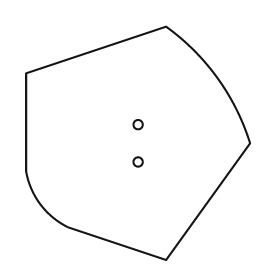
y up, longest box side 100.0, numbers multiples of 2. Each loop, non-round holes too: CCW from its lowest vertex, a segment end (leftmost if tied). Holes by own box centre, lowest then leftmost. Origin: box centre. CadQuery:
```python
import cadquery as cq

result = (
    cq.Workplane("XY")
    .moveTo(12.0, -50.0)
    .lineTo(48.0, 0.0)
    .threePointArc((34.0, 28.0), (12.0, 50.0))
    .lineTo(-48.0, 30.0)
    .lineTo(-48.0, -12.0)
    .threePointArc((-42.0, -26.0), (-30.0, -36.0))
    .close()
    .moveTo(0.0, -8.0)
    .circle(2.0)
    .moveTo(0.0, 8.0)
    .circle(2.0)
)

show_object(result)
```